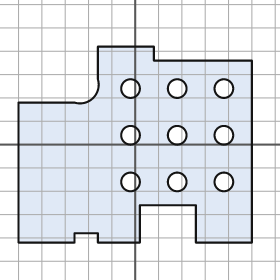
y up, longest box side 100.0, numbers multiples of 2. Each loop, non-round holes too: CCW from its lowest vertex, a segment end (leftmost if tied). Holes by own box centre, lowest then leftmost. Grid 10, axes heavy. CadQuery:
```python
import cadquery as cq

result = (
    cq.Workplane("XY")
    .moveTo(-50.0, -42.0)
    .lineTo(-26.0, -42.0)
    .lineTo(-26.0, -38.0)
    .lineTo(-16.0, -38.0)
    .lineTo(-16.0, -42.0)
    .lineTo(2.0, -42.0)
    .lineTo(2.0, -26.0)
    .lineTo(26.0, -26.0)
    .lineTo(26.0, -42.0)
    .lineTo(50.0, -42.0)
    .lineTo(50.0, 36.0)
    .lineTo(8.0, 36.0)
    .lineTo(8.0, 42.0)
    .lineTo(-16.0, 42.0)
    .lineTo(-16.0, 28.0)
    .threePointArc((-18.0, 20.0), (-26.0, 18.0))
    .lineTo(-50.0, 18.0)
    .close()
    .moveTo(-2.0, -16.0)
    .circle(4.0)
    .moveTo(18.0, -16.0)
    .circle(4.0)
    .moveTo(38.0, -16.0)
    .circle(4.0)
    .moveTo(-2.0, 4.0)
    .circle(4.0)
    .moveTo(18.0, 4.0)
    .circle(4.0)
    .moveTo(38.0, 4.0)
    .circle(4.0)
    .moveTo(-2.0, 24.0)
    .circle(4.0)
    .moveTo(18.0, 24.0)
    .circle(4.0)
    .moveTo(38.0, 24.0)
    .circle(4.0)
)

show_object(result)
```